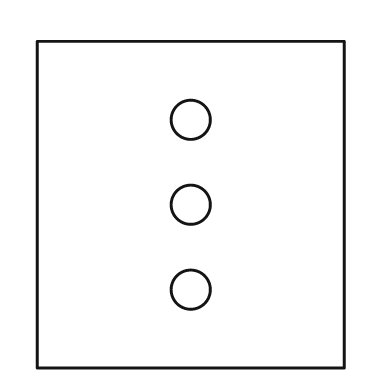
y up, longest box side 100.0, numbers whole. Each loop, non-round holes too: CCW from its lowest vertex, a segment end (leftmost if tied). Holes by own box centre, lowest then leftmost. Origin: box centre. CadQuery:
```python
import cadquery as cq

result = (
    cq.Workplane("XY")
    .moveTo(-47.0, -50.0)
    .lineTo(47.0, -50.0)
    .lineTo(47.0, 50.0)
    .lineTo(-47.0, 50.0)
    .close()
    .moveTo(0.0, -26.0)
    .circle(6.0)
    .moveTo(0.0, 0.0)
    .circle(6.0)
    .moveTo(0.0, 26.0)
    .circle(6.0)
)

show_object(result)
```